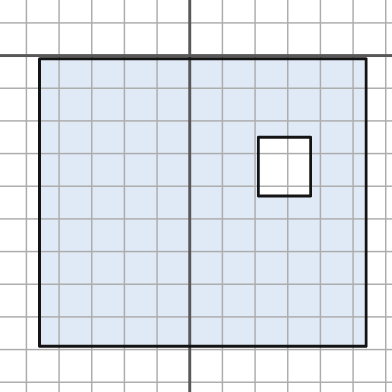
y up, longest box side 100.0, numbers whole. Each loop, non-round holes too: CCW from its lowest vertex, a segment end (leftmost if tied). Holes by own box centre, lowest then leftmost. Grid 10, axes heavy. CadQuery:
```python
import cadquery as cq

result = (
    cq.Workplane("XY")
    .moveTo(-46.0, -89.0)
    .lineTo(54.0, -89.0)
    .lineTo(54.0, -1.0)
    .lineTo(-46.0, -1.0)
    .close()
    .moveTo(21.0, -43.0)
    .lineTo(37.0, -43.0)
    .lineTo(37.0, -25.0)
    .lineTo(21.0, -25.0)
    .close()
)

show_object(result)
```